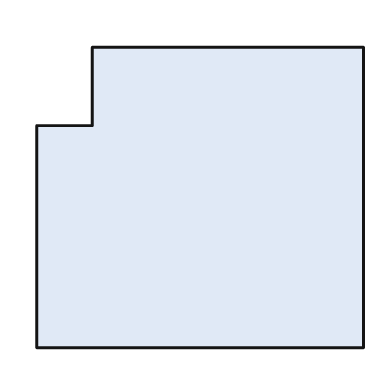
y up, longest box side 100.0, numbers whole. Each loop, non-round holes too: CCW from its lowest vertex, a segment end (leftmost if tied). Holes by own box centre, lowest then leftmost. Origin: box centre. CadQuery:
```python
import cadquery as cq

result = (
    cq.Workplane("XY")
    .moveTo(-50.0, -46.0)
    .lineTo(50.0, -46.0)
    .lineTo(50.0, 46.0)
    .lineTo(-33.0, 46.0)
    .lineTo(-33.0, 22.0)
    .lineTo(-50.0, 22.0)
    .close()
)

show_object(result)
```